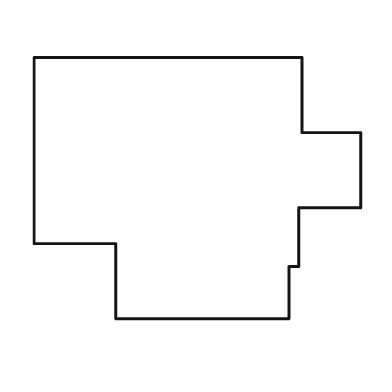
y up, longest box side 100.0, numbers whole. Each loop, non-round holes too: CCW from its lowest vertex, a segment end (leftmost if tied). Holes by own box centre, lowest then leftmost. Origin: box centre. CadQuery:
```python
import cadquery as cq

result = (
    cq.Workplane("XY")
    .moveTo(-25.0, -40.0)
    .lineTo(28.0, -40.0)
    .lineTo(28.0, -24.0)
    .lineTo(31.0, -24.0)
    .lineTo(31.0, -6.0)
    .lineTo(50.0, -6.0)
    .lineTo(50.0, 17.0)
    .lineTo(32.0, 17.0)
    .lineTo(32.0, 40.0)
    .lineTo(-50.0, 40.0)
    .lineTo(-50.0, -17.0)
    .lineTo(-25.0, -17.0)
    .close()
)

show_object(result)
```